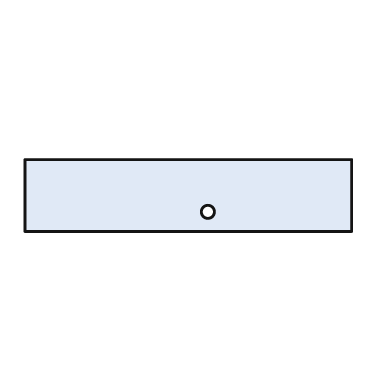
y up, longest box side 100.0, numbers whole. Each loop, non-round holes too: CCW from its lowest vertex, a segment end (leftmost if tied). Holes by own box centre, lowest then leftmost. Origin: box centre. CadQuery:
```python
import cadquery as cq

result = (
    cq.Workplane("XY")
    .moveTo(-50.0, -11.0)
    .lineTo(50.0, -11.0)
    .lineTo(50.0, 11.0)
    .lineTo(-50.0, 11.0)
    .close()
    .moveTo(6.0, -5.0)
    .circle(2.0)
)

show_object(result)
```